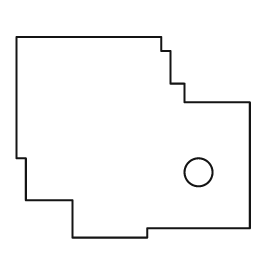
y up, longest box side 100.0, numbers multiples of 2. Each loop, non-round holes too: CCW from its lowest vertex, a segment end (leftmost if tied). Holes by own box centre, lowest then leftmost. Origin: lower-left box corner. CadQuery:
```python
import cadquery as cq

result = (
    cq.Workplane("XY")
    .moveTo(24.0, 0.0)
    .lineTo(56.0, 0.0)
    .lineTo(56.0, 4.0)
    .lineTo(100.0, 4.0)
    .lineTo(100.0, 58.0)
    .lineTo(72.0, 58.0)
    .lineTo(72.0, 66.0)
    .lineTo(66.0, 66.0)
    .lineTo(66.0, 80.0)
    .lineTo(62.0, 80.0)
    .lineTo(62.0, 86.0)
    .lineTo(0.0, 86.0)
    .lineTo(0.0, 34.0)
    .lineTo(4.0, 34.0)
    .lineTo(4.0, 16.0)
    .lineTo(24.0, 16.0)
    .close()
    .moveTo(78.0, 28.0)
    .circle(6.0)
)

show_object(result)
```